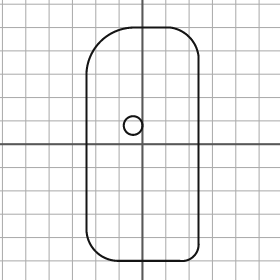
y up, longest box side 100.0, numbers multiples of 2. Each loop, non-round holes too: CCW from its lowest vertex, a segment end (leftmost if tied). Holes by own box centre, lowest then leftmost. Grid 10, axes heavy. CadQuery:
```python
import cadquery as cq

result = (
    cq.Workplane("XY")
    .moveTo(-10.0, -50.0)
    .lineTo(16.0, -50.0)
    .threePointArc((22.0, -48.0), (24.0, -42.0))
    .lineTo(24.0, 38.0)
    .threePointArc((20.0, 46.0), (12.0, 50.0))
    .lineTo(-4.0, 50.0)
    .threePointArc((-18.0, 44.0), (-24.0, 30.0))
    .lineTo(-24.0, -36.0)
    .threePointArc((-20.0, -46.0), (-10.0, -50.0))
    .close()
    .moveTo(-4.0, 8.0)
    .circle(4.0)
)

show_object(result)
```